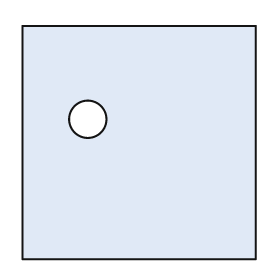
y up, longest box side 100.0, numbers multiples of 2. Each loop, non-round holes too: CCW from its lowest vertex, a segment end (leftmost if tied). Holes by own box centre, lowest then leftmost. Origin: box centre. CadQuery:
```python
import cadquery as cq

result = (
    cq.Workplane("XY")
    .moveTo(-50.0, -50.0)
    .lineTo(50.0, -50.0)
    .lineTo(50.0, 50.0)
    .lineTo(-50.0, 50.0)
    .close()
    .moveTo(-22.0, 10.0)
    .circle(8.0)
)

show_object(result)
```